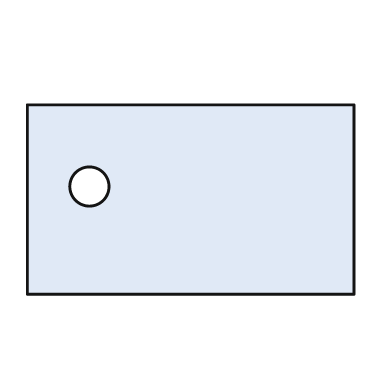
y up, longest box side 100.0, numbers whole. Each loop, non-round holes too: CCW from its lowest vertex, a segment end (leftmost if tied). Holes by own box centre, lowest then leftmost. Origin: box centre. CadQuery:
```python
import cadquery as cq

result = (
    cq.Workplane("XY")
    .moveTo(-50.0, -29.0)
    .lineTo(50.0, -29.0)
    .lineTo(50.0, 29.0)
    .lineTo(-50.0, 29.0)
    .close()
    .moveTo(-31.0, 4.0)
    .circle(6.0)
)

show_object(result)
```